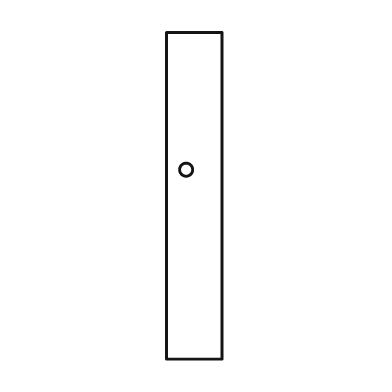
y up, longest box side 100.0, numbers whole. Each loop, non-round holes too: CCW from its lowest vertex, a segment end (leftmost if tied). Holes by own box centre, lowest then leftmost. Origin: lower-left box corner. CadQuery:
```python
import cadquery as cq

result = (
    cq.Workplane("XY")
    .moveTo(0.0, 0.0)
    .lineTo(17.0, 0.0)
    .lineTo(17.0, 100.0)
    .lineTo(0.0, 100.0)
    .close()
    .moveTo(6.0, 58.0)
    .circle(2.0)
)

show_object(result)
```